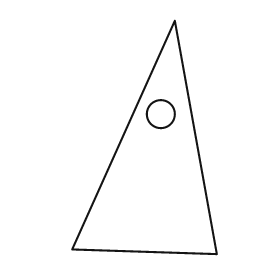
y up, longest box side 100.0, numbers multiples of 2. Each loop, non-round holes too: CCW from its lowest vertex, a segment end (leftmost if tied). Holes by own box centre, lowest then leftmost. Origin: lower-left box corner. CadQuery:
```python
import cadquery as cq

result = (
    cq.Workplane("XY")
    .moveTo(62.0, 0.0)
    .lineTo(44.0, 100.0)
    .lineTo(0.0, 2.0)
    .close()
    .moveTo(38.0, 60.0)
    .circle(6.0)
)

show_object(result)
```